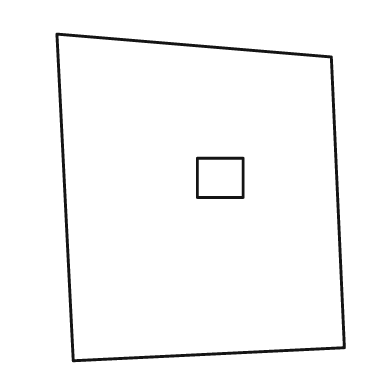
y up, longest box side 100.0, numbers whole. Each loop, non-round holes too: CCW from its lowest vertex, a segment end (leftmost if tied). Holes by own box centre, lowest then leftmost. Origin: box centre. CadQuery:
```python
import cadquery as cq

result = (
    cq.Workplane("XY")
    .moveTo(-39.0, -50.0)
    .lineTo(44.0, -46.0)
    .lineTo(40.0, 43.0)
    .lineTo(-44.0, 50.0)
    .close()
    .moveTo(-1.0, 0.0)
    .lineTo(13.0, 0.0)
    .lineTo(13.0, 12.0)
    .lineTo(-1.0, 12.0)
    .close()
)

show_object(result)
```